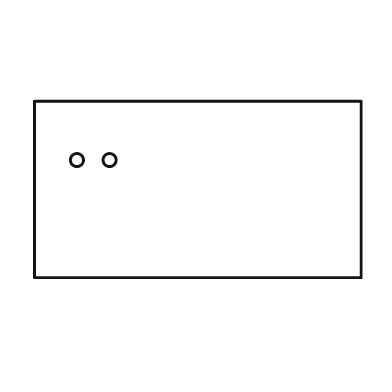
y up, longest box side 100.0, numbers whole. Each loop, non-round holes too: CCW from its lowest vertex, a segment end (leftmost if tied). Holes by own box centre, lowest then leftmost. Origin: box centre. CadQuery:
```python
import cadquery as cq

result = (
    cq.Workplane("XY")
    .moveTo(-50.0, -27.0)
    .lineTo(50.0, -27.0)
    .lineTo(50.0, 27.0)
    .lineTo(-50.0, 27.0)
    .close()
    .moveTo(-37.0, 9.0)
    .circle(2.0)
    .moveTo(-27.0, 9.0)
    .circle(2.0)
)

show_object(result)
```